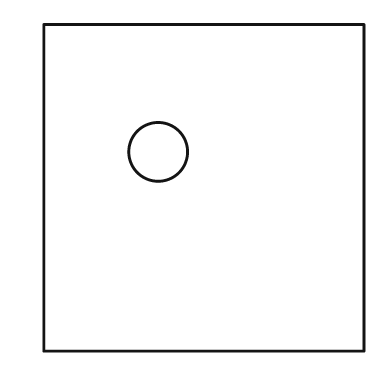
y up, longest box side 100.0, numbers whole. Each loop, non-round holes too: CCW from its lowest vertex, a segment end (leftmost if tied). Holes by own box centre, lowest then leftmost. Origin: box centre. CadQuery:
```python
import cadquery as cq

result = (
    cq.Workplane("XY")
    .moveTo(-49.0, -50.0)
    .lineTo(49.0, -50.0)
    .lineTo(49.0, 50.0)
    .lineTo(-49.0, 50.0)
    .close()
    .moveTo(-14.0, 11.0)
    .circle(9.0)
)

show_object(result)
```